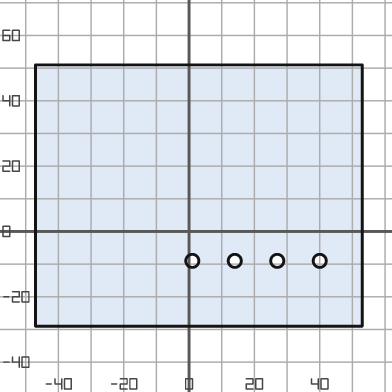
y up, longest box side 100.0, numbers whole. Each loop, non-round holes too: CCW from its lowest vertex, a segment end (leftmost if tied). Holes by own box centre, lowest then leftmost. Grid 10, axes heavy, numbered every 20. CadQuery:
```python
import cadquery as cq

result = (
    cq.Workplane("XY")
    .moveTo(-47.0, -29.0)
    .lineTo(53.0, -29.0)
    .lineTo(53.0, 51.0)
    .lineTo(-47.0, 51.0)
    .close()
    .moveTo(1.0, -9.0)
    .circle(2.0)
    .moveTo(14.0, -9.0)
    .circle(2.0)
    .moveTo(27.0, -9.0)
    .circle(2.0)
    .moveTo(40.0, -9.0)
    .circle(2.0)
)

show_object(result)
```